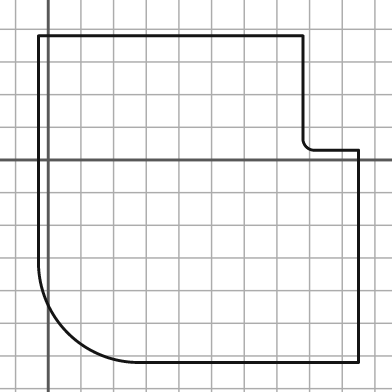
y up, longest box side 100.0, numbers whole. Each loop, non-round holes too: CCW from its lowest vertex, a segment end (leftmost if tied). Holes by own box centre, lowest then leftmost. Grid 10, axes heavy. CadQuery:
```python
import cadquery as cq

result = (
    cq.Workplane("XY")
    .moveTo(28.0, -62.0)
    .lineTo(95.0, -62.0)
    .lineTo(95.0, 3.0)
    .lineTo(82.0, 3.0)
    .threePointArc((79.0, 4.0), (78.0, 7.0))
    .lineTo(78.0, 38.0)
    .lineTo(-3.0, 38.0)
    .lineTo(-3.0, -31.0)
    .threePointArc((6.0, -53.0), (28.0, -62.0))
    .close()
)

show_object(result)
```